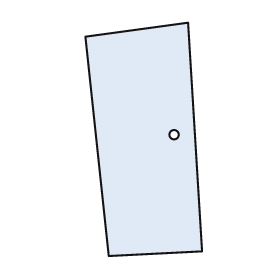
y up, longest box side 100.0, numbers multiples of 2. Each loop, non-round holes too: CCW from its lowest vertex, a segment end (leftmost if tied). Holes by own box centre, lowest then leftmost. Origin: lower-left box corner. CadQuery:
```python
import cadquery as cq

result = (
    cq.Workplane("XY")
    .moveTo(10.0, 0.0)
    .lineTo(50.0, 2.0)
    .lineTo(44.0, 100.0)
    .lineTo(0.0, 94.0)
    .close()
    .moveTo(38.0, 52.0)
    .circle(2.0)
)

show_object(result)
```